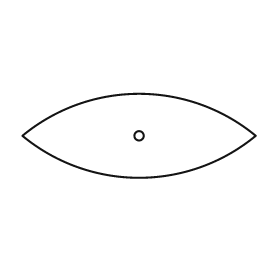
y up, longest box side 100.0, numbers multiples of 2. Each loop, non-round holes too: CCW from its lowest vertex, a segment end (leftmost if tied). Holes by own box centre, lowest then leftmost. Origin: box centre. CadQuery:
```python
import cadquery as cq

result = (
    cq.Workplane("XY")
    .moveTo(-50.0, 0.0)
    .threePointArc((0.0, -18.0), (50.0, 0.0))
    .threePointArc((0.0, 18.0), (-50.0, 0.0))
    .close()
    .moveTo(0.0, 0.0)
    .circle(2.0)
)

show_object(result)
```